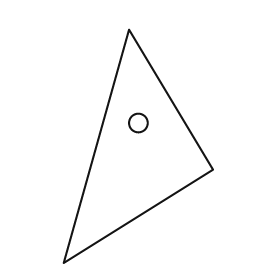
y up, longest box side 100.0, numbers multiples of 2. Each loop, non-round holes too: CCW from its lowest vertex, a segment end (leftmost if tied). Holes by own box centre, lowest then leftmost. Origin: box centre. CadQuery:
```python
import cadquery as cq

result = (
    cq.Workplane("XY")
    .moveTo(-32.0, -50.0)
    .lineTo(32.0, -10.0)
    .lineTo(-4.0, 50.0)
    .close()
    .moveTo(0.0, 10.0)
    .circle(4.0)
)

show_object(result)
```